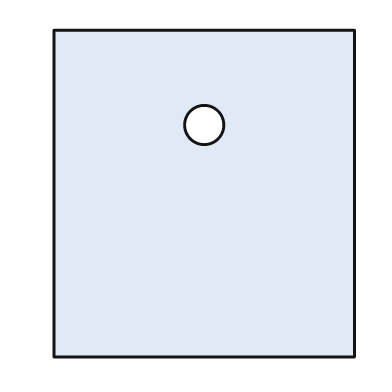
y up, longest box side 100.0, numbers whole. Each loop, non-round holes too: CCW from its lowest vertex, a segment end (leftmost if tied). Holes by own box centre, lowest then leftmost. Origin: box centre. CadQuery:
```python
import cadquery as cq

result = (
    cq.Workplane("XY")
    .moveTo(-46.0, -50.0)
    .lineTo(46.0, -50.0)
    .lineTo(46.0, 50.0)
    .lineTo(-46.0, 50.0)
    .close()
    .moveTo(0.0, 21.0)
    .circle(6.0)
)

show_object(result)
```